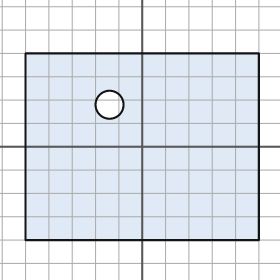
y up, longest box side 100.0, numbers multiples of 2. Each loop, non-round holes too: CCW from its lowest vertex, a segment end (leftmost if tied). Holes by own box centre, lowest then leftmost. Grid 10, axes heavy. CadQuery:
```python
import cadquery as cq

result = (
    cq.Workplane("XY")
    .moveTo(-50.0, -40.0)
    .lineTo(50.0, -40.0)
    .lineTo(50.0, 40.0)
    .lineTo(-50.0, 40.0)
    .close()
    .moveTo(-14.0, 18.0)
    .circle(6.0)
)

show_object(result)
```